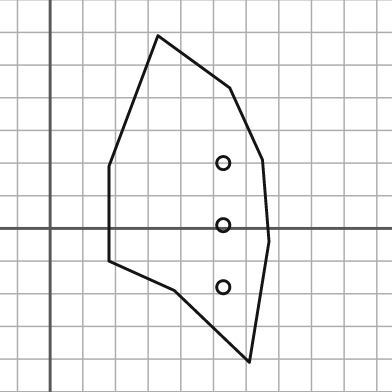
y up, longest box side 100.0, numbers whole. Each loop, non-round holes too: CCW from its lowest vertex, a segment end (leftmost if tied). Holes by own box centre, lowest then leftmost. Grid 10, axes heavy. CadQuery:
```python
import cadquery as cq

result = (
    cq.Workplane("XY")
    .moveTo(61.0, -41.0)
    .lineTo(67.0, -4.0)
    .lineTo(65.0, 21.0)
    .lineTo(55.0, 43.0)
    .lineTo(33.0, 59.0)
    .lineTo(18.0, 19.0)
    .lineTo(18.0, -10.0)
    .lineTo(38.0, -19.0)
    .close()
    .moveTo(53.0, -18.0)
    .circle(2.0)
    .moveTo(53.0, 1.0)
    .circle(2.0)
    .moveTo(53.0, 20.0)
    .circle(2.0)
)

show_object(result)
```